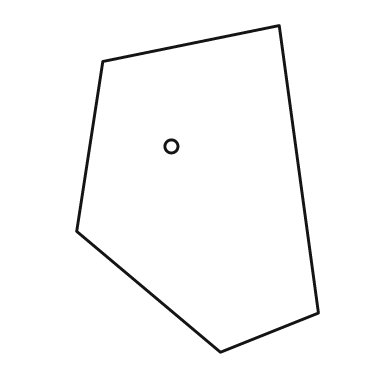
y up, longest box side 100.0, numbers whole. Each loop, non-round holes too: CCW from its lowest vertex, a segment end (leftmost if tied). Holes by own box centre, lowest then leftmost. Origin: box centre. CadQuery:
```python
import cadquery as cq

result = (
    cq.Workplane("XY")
    .moveTo(7.0, -50.0)
    .lineTo(37.0, -38.0)
    .lineTo(25.0, 50.0)
    .lineTo(-29.0, 39.0)
    .lineTo(-37.0, -13.0)
    .close()
    .moveTo(-8.0, 13.0)
    .circle(2.0)
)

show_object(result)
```